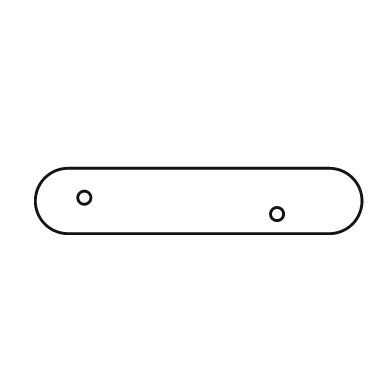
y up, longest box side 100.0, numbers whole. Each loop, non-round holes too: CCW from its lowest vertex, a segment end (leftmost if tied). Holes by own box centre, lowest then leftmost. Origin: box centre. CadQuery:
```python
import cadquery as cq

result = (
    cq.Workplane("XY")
    .moveTo(-40.0, -10.0)
    .lineTo(40.0, -10.0)
    .threePointArc((50.0, 0.0), (40.0, 10.0))
    .lineTo(-40.0, 10.0)
    .threePointArc((-50.0, 0.0), (-40.0, -10.0))
    .close()
    .moveTo(24.0, -4.0)
    .circle(2.0)
    .moveTo(-35.0, 1.0)
    .circle(2.0)
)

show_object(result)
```